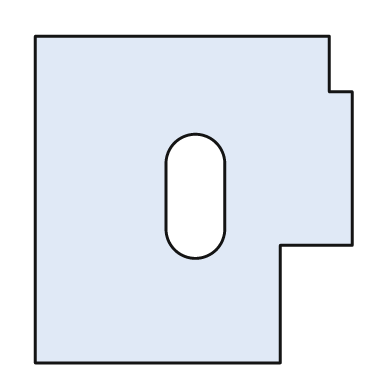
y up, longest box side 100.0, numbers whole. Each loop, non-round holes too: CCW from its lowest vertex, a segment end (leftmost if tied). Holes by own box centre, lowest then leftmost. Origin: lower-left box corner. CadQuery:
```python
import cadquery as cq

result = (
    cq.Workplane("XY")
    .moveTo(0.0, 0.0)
    .lineTo(75.0, 0.0)
    .lineTo(75.0, 36.0)
    .lineTo(97.0, 36.0)
    .lineTo(97.0, 83.0)
    .lineTo(90.0, 83.0)
    .lineTo(90.0, 100.0)
    .lineTo(0.0, 100.0)
    .close()
    .moveTo(40.0, 41.0)
    .threePointArc((49.0, 32.0), (58.0, 41.0))
    .lineTo(58.0, 61.0)
    .threePointArc((49.0, 70.0), (40.0, 61.0))
    .close()
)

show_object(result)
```